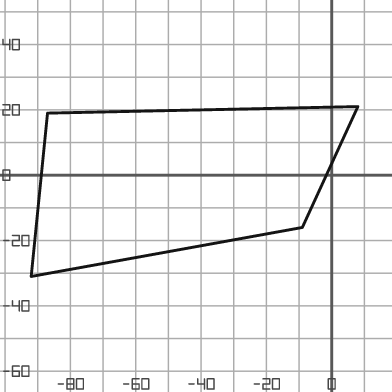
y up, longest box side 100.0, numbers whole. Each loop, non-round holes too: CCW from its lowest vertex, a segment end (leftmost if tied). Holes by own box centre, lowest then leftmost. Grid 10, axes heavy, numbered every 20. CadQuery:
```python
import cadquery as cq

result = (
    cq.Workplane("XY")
    .moveTo(-92.0, -31.0)
    .lineTo(-9.0, -16.0)
    .lineTo(8.0, 21.0)
    .lineTo(-87.0, 19.0)
    .close()
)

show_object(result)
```